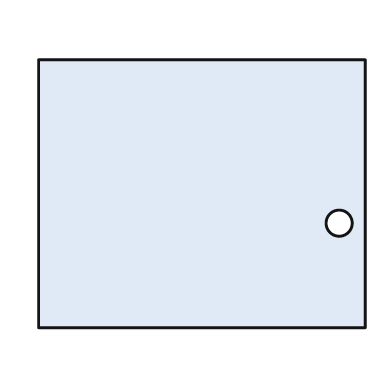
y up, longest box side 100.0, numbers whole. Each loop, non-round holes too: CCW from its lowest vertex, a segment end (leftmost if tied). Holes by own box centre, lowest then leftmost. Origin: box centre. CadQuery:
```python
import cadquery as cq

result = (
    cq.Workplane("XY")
    .moveTo(-50.0, -41.0)
    .lineTo(50.0, -41.0)
    .lineTo(50.0, 41.0)
    .lineTo(-50.0, 41.0)
    .close()
    .moveTo(42.0, -9.0)
    .circle(4.0)
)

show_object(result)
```